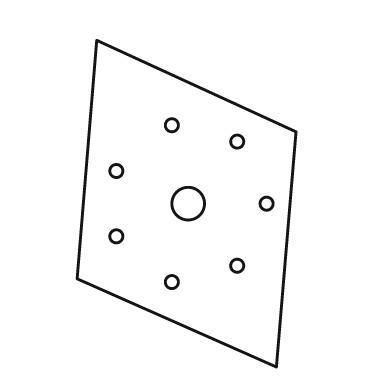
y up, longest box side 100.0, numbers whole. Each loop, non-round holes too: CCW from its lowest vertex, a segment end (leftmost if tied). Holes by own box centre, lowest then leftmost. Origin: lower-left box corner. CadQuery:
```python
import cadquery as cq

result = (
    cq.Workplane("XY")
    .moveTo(61.0, 0.0)
    .lineTo(67.0, 72.0)
    .lineTo(6.0, 100.0)
    .lineTo(0.0, 27.0)
    .close()
    .moveTo(29.0, 26.0)
    .circle(2.0)
    .moveTo(49.0, 31.0)
    .circle(2.0)
    .moveTo(12.0, 40.0)
    .circle(2.0)
    .moveTo(34.0, 50.0)
    .circle(5.0)
    .moveTo(58.0, 50.0)
    .circle(2.0)
    .moveTo(12.0, 60.0)
    .circle(2.0)
    .moveTo(49.0, 69.0)
    .circle(2.0)
    .moveTo(29.0, 74.0)
    .circle(2.0)
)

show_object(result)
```